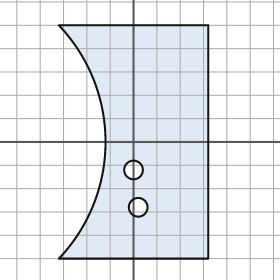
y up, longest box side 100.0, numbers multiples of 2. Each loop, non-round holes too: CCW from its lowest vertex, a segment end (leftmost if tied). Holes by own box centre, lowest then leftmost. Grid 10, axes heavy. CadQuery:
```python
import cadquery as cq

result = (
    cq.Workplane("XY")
    .moveTo(-32.0, -50.0)
    .lineTo(32.0, -50.0)
    .lineTo(32.0, 50.0)
    .lineTo(-32.0, 50.0)
    .threePointArc((-12.0, 0.0), (-32.0, -50.0))
    .close()
    .moveTo(2.0, -28.0)
    .circle(4.0)
    .moveTo(0.0, -12.0)
    .circle(4.0)
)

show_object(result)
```